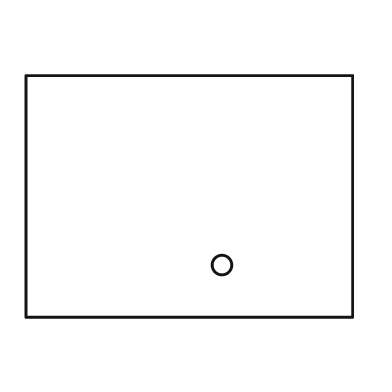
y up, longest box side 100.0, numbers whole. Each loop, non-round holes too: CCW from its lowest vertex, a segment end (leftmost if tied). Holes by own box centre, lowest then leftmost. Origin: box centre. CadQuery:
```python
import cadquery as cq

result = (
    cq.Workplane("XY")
    .moveTo(-50.0, -37.0)
    .lineTo(50.0, -37.0)
    .lineTo(50.0, 37.0)
    .lineTo(-50.0, 37.0)
    .close()
    .moveTo(10.0, -21.0)
    .circle(3.0)
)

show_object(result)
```